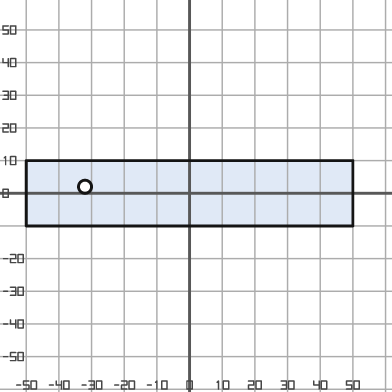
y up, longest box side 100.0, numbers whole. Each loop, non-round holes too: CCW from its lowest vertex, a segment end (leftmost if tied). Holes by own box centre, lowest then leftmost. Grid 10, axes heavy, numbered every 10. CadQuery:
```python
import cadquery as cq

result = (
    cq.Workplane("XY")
    .moveTo(-50.0, -10.0)
    .lineTo(50.0, -10.0)
    .lineTo(50.0, 10.0)
    .lineTo(-50.0, 10.0)
    .close()
    .moveTo(-32.0, 2.0)
    .circle(2.0)
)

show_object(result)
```